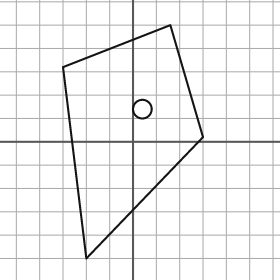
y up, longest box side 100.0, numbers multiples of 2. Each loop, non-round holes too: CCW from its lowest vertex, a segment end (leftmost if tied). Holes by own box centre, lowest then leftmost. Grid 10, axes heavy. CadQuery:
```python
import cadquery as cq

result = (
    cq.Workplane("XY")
    .moveTo(-20.0, -50.0)
    .lineTo(30.0, 2.0)
    .lineTo(16.0, 50.0)
    .lineTo(-30.0, 32.0)
    .close()
    .moveTo(4.0, 14.0)
    .circle(4.0)
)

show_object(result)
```